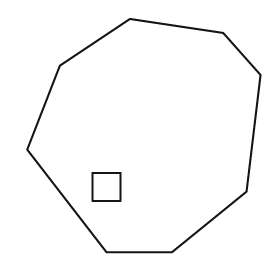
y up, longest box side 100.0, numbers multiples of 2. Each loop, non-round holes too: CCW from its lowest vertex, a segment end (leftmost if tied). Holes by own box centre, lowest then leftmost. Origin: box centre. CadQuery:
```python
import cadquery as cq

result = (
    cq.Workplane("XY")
    .moveTo(-16.0, -50.0)
    .lineTo(12.0, -50.0)
    .lineTo(44.0, -24.0)
    .lineTo(50.0, 26.0)
    .lineTo(34.0, 44.0)
    .lineTo(-6.0, 50.0)
    .lineTo(-36.0, 30.0)
    .lineTo(-50.0, -6.0)
    .close()
    .moveTo(-22.0, -28.0)
    .lineTo(-10.0, -28.0)
    .lineTo(-10.0, -16.0)
    .lineTo(-22.0, -16.0)
    .close()
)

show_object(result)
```